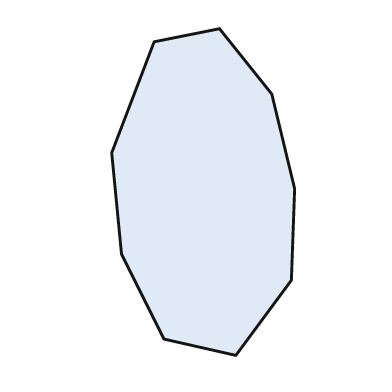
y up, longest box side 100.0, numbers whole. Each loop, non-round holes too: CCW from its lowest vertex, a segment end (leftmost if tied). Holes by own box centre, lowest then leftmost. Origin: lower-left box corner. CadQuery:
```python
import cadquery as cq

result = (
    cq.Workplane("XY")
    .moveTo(38.0, 0.0)
    .lineTo(55.0, 23.0)
    .lineTo(56.0, 51.0)
    .lineTo(49.0, 80.0)
    .lineTo(33.0, 100.0)
    .lineTo(13.0, 96.0)
    .lineTo(0.0, 62.0)
    .lineTo(3.0, 31.0)
    .lineTo(16.0, 5.0)
    .close()
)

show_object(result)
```